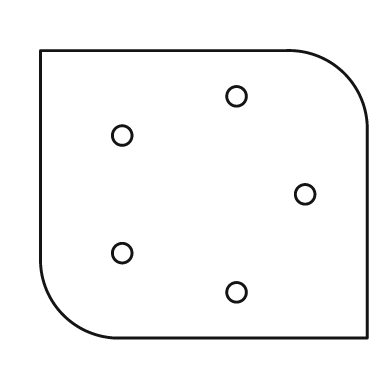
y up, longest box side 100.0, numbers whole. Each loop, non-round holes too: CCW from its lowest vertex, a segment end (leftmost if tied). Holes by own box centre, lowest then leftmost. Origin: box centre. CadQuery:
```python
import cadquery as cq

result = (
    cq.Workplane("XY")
    .moveTo(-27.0, -44.0)
    .lineTo(50.0, -44.0)
    .lineTo(50.0, 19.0)
    .threePointArc((43.0, 37.0), (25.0, 44.0))
    .lineTo(-50.0, 44.0)
    .lineTo(-50.0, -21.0)
    .threePointArc((-43.0, -37.0), (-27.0, -44.0))
    .close()
    .moveTo(10.0, -30.0)
    .circle(3.0)
    .moveTo(-25.0, -18.0)
    .circle(3.0)
    .moveTo(31.0, 0.0)
    .circle(3.0)
    .moveTo(-25.0, 18.0)
    .circle(3.0)
    .moveTo(10.0, 30.0)
    .circle(3.0)
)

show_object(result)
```